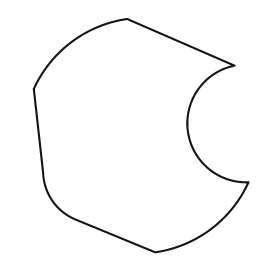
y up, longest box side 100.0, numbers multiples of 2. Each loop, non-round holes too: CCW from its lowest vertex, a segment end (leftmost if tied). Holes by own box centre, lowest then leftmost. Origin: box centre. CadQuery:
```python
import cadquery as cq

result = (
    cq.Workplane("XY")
    .moveTo(6.0, -50.0)
    .threePointArc((30.0, -40.0), (46.0, -20.0))
    .threePointArc((20.0, 2.0), (40.0, 30.0))
    .lineTo(-6.0, 50.0)
    .threePointArc((-30.0, 40.0), (-46.0, 20.0))
    .lineTo(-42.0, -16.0)
    .threePointArc((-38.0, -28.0), (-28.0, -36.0))
    .close()
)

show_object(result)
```